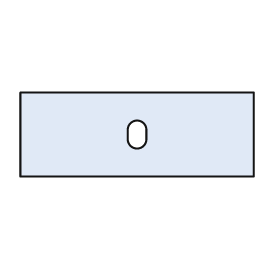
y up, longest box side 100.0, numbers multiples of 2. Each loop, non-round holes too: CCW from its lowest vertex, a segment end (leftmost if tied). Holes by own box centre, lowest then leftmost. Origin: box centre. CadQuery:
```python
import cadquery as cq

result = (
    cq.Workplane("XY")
    .moveTo(-50.0, -18.0)
    .lineTo(50.0, -18.0)
    .lineTo(50.0, 18.0)
    .lineTo(-50.0, 18.0)
    .close()
    .moveTo(-4.0, -2.0)
    .threePointArc((0.0, -6.0), (4.0, -2.0))
    .lineTo(4.0, 2.0)
    .threePointArc((0.0, 6.0), (-4.0, 2.0))
    .close()
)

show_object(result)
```